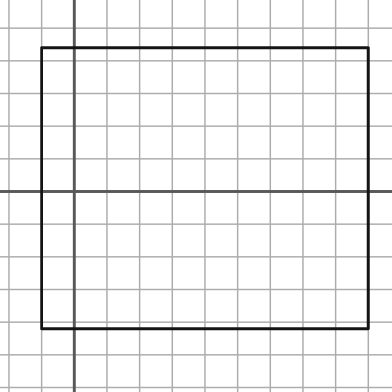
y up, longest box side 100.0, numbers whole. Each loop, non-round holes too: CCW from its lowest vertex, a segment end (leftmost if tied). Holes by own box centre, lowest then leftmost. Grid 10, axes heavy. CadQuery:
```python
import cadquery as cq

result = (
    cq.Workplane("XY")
    .moveTo(-10.0, -42.0)
    .lineTo(90.0, -42.0)
    .lineTo(90.0, 44.0)
    .lineTo(-10.0, 44.0)
    .close()
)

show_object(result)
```